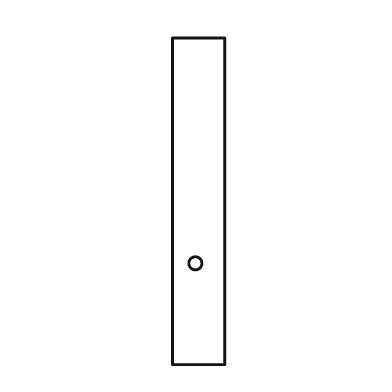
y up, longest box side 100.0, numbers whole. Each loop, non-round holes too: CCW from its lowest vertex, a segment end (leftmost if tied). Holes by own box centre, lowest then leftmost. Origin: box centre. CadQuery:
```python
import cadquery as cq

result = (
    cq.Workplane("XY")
    .moveTo(-8.0, -50.0)
    .lineTo(8.0, -50.0)
    .lineTo(8.0, 50.0)
    .lineTo(-8.0, 50.0)
    .close()
    .moveTo(-1.0, -19.0)
    .circle(2.0)
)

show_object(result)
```